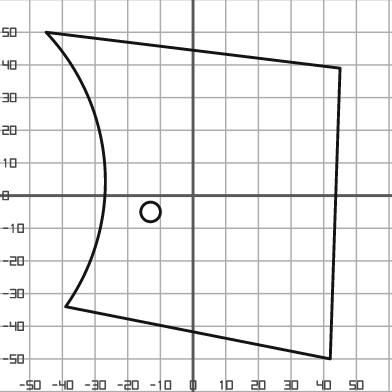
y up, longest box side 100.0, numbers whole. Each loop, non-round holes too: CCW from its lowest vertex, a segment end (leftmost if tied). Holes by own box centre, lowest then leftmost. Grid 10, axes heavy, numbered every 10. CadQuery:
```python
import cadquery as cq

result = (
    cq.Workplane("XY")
    .moveTo(42.0, -50.0)
    .lineTo(45.0, 39.0)
    .lineTo(-45.0, 50.0)
    .threePointArc((-27.0, 9.0), (-39.0, -34.0))
    .close()
    .moveTo(-13.0, -5.0)
    .circle(3.0)
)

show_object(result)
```